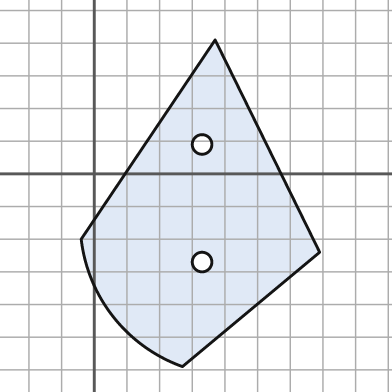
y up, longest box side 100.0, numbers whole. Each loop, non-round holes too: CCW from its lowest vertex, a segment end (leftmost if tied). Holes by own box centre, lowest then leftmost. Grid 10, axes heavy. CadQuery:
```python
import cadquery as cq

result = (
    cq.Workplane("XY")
    .moveTo(27.0, -59.0)
    .lineTo(69.0, -24.0)
    .lineTo(37.0, 41.0)
    .lineTo(-4.0, -20.0)
    .threePointArc((6.0, -44.0), (27.0, -59.0))
    .close()
    .moveTo(33.0, -27.0)
    .circle(3.0)
    .moveTo(33.0, 9.0)
    .circle(3.0)
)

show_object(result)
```